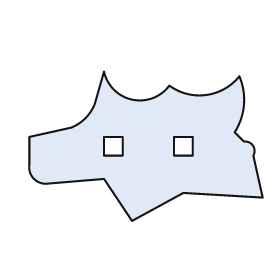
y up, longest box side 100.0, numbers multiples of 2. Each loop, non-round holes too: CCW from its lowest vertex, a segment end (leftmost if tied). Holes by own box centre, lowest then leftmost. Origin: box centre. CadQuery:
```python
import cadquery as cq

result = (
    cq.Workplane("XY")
    .moveTo(-6.0, -32.0)
    .lineTo(16.0, -20.0)
    .lineTo(50.0, -22.0)
    .lineTo(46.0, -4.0)
    .threePointArc((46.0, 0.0), (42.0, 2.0))
    .lineTo(38.0, 6.0)
    .threePointArc((42.0, 18.0), (40.0, 30.0))
    .threePointArc((26.0, 22.0), (10.0, 26.0))
    .threePointArc((-6.0, 20.0), (-18.0, 32.0))
    .lineTo(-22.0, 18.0)
    .threePointArc((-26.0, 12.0), (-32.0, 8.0))
    .lineTo(-50.0, 4.0)
    .lineTo(-50.0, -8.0)
    .threePointArc((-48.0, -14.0), (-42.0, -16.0))
    .lineTo(-18.0, -14.0)
    .close()
    .moveTo(-18.0, -4.0)
    .lineTo(-10.0, -4.0)
    .lineTo(-10.0, 4.0)
    .lineTo(-18.0, 4.0)
    .close()
    .moveTo(12.0, -4.0)
    .lineTo(20.0, -4.0)
    .lineTo(20.0, 4.0)
    .lineTo(12.0, 4.0)
    .close()
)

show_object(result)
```